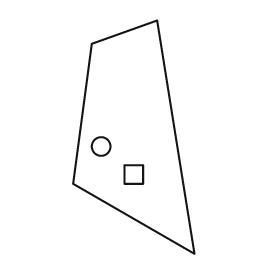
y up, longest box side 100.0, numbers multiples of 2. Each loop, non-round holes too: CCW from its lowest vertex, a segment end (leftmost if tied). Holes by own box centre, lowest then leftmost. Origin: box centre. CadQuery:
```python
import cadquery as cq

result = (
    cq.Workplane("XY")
    .moveTo(26.0, -50.0)
    .lineTo(10.0, 50.0)
    .lineTo(-18.0, 40.0)
    .lineTo(-26.0, -20.0)
    .close()
    .moveTo(-4.0, -20.0)
    .lineTo(4.0, -20.0)
    .lineTo(4.0, -12.0)
    .lineTo(-4.0, -12.0)
    .close()
    .moveTo(-14.0, -4.0)
    .circle(4.0)
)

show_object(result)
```